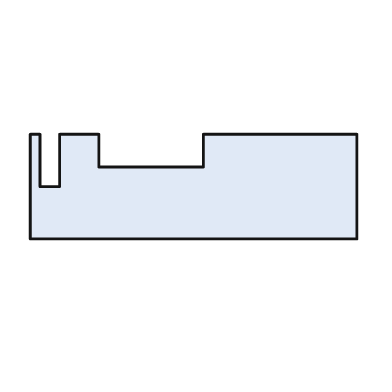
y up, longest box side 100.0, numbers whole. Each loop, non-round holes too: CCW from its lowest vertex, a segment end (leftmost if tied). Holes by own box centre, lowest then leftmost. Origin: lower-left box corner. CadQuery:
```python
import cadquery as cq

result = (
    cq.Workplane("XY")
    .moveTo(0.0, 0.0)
    .lineTo(100.0, 0.0)
    .lineTo(100.0, 32.0)
    .lineTo(53.0, 32.0)
    .lineTo(53.0, 22.0)
    .lineTo(21.0, 22.0)
    .lineTo(21.0, 32.0)
    .lineTo(9.0, 32.0)
    .lineTo(9.0, 16.0)
    .lineTo(3.0, 16.0)
    .lineTo(3.0, 32.0)
    .lineTo(0.0, 32.0)
    .close()
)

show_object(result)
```